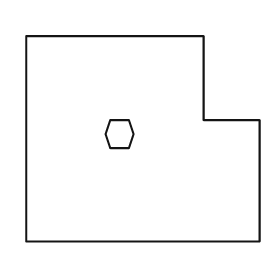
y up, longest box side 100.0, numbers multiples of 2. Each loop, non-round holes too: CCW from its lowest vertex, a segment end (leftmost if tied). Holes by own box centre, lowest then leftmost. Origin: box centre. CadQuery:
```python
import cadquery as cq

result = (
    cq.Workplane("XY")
    .moveTo(-50.0, -44.0)
    .lineTo(50.0, -44.0)
    .lineTo(50.0, 8.0)
    .lineTo(26.0, 8.0)
    .lineTo(26.0, 44.0)
    .lineTo(-50.0, 44.0)
    .close()
    .moveTo(-14.0, -4.0)
    .lineTo(-6.0, -4.0)
    .lineTo(-4.0, 2.0)
    .lineTo(-6.0, 8.0)
    .lineTo(-14.0, 8.0)
    .lineTo(-16.0, 2.0)
    .close()
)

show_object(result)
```